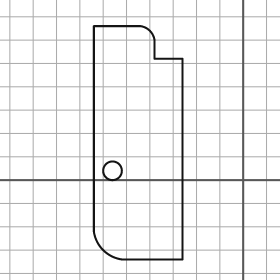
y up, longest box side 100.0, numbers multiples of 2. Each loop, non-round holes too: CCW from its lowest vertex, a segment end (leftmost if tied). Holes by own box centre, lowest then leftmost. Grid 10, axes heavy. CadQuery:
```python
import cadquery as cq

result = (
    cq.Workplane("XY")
    .moveTo(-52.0, -34.0)
    .lineTo(-26.0, -34.0)
    .lineTo(-26.0, 52.0)
    .lineTo(-38.0, 52.0)
    .lineTo(-38.0, 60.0)
    .threePointArc((-40.0, 64.0), (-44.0, 66.0))
    .lineTo(-64.0, 66.0)
    .lineTo(-64.0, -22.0)
    .threePointArc((-60.0, -30.0), (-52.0, -34.0))
    .close()
    .moveTo(-56.0, 4.0)
    .circle(4.0)
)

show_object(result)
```